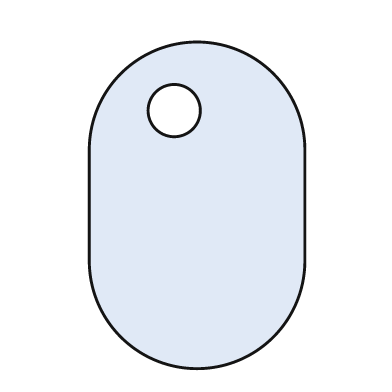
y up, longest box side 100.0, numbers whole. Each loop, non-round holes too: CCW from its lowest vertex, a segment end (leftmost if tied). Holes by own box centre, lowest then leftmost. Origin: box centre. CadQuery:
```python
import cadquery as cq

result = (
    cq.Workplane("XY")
    .moveTo(-33.0, -17.0)
    .threePointArc((0.0, -50.0), (33.0, -17.0))
    .lineTo(33.0, 17.0)
    .threePointArc((0.0, 50.0), (-33.0, 17.0))
    .close()
    .moveTo(-7.0, 29.0)
    .circle(8.0)
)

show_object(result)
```